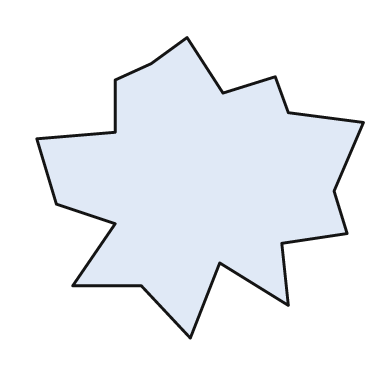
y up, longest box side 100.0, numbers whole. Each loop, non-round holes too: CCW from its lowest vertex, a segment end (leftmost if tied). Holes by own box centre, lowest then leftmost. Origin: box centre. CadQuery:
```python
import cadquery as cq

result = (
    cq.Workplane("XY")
    .moveTo(-3.0, -46.0)
    .lineTo(6.0, -23.0)
    .lineTo(27.0, -36.0)
    .lineTo(25.0, -17.0)
    .lineTo(45.0, -14.0)
    .lineTo(41.0, -1.0)
    .lineTo(50.0, 20.0)
    .lineTo(27.0, 23.0)
    .lineTo(23.0, 34.0)
    .lineTo(7.0, 29.0)
    .lineTo(-4.0, 46.0)
    .lineTo(-15.0, 38.0)
    .lineTo(-26.0, 33.0)
    .lineTo(-26.0, 17.0)
    .lineTo(-50.0, 15.0)
    .lineTo(-44.0, -5.0)
    .lineTo(-26.0, -11.0)
    .lineTo(-39.0, -30.0)
    .lineTo(-18.0, -30.0)
    .close()
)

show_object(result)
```